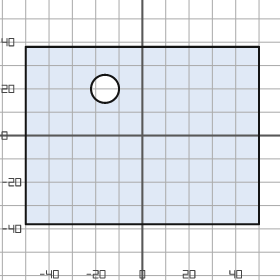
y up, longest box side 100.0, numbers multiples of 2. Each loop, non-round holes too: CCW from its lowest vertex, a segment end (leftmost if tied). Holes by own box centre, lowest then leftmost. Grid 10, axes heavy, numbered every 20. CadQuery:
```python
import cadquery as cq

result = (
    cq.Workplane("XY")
    .moveTo(-50.0, -38.0)
    .lineTo(50.0, -38.0)
    .lineTo(50.0, 38.0)
    .lineTo(-50.0, 38.0)
    .close()
    .moveTo(-16.0, 20.0)
    .circle(6.0)
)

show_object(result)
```